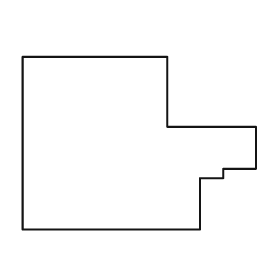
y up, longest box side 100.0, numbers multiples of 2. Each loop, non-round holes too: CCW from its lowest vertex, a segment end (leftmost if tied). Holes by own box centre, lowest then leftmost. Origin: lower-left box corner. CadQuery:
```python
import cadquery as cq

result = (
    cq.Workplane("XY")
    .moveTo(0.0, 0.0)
    .lineTo(76.0, 0.0)
    .lineTo(76.0, 22.0)
    .lineTo(86.0, 22.0)
    .lineTo(86.0, 26.0)
    .lineTo(100.0, 26.0)
    .lineTo(100.0, 44.0)
    .lineTo(62.0, 44.0)
    .lineTo(62.0, 74.0)
    .lineTo(0.0, 74.0)
    .close()
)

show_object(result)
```